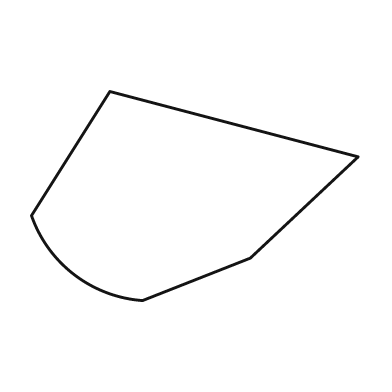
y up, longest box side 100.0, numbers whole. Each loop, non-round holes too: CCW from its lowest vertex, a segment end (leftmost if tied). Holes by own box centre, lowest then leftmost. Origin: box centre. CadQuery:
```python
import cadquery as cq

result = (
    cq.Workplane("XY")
    .moveTo(-16.0, -32.0)
    .lineTo(17.0, -19.0)
    .lineTo(50.0, 12.0)
    .lineTo(-26.0, 32.0)
    .lineTo(-50.0, -6.0)
    .threePointArc((-37.0, -24.0), (-16.0, -32.0))
    .close()
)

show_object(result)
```